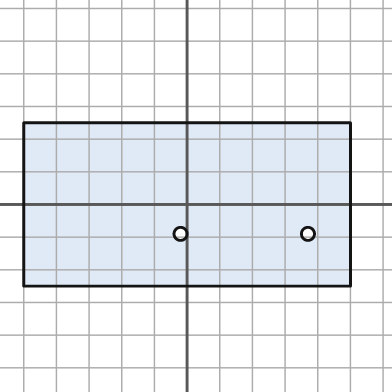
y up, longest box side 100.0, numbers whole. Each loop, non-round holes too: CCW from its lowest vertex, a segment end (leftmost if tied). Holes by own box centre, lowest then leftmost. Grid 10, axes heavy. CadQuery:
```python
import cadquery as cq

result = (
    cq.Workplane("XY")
    .moveTo(-50.0, -25.0)
    .lineTo(50.0, -25.0)
    .lineTo(50.0, 25.0)
    .lineTo(-50.0, 25.0)
    .close()
    .moveTo(-2.0, -9.0)
    .circle(2.0)
    .moveTo(37.0, -9.0)
    .circle(2.0)
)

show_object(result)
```